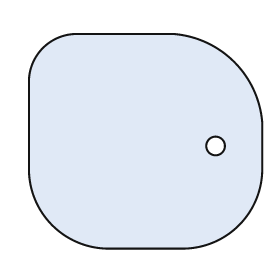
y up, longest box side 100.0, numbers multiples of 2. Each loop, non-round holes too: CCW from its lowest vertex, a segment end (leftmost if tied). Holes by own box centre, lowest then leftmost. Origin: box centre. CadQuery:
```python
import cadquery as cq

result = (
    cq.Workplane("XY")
    .moveTo(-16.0, -46.0)
    .lineTo(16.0, -46.0)
    .threePointArc((40.0, -36.0), (50.0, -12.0))
    .lineTo(50.0, 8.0)
    .threePointArc((38.0, 34.0), (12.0, 46.0))
    .lineTo(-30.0, 46.0)
    .threePointArc((-44.0, 40.0), (-50.0, 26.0))
    .lineTo(-50.0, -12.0)
    .threePointArc((-40.0, -36.0), (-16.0, -46.0))
    .close()
    .moveTo(30.0, -2.0)
    .circle(4.0)
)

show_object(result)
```